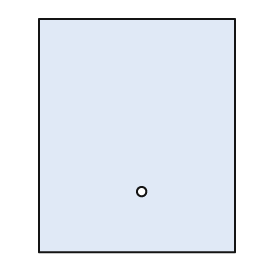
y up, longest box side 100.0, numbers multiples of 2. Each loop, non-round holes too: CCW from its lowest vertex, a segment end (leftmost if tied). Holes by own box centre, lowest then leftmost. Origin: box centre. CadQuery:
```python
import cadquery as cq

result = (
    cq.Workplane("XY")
    .moveTo(-42.0, -50.0)
    .lineTo(42.0, -50.0)
    .lineTo(42.0, 50.0)
    .lineTo(-42.0, 50.0)
    .close()
    .moveTo(2.0, -24.0)
    .circle(2.0)
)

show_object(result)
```